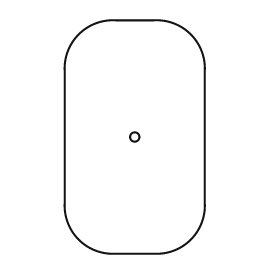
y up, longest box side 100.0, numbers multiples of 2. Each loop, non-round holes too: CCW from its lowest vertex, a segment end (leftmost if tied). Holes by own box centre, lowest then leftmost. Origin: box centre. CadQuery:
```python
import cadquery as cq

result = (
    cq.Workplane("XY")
    .moveTo(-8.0, -50.0)
    .lineTo(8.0, -50.0)
    .threePointArc((24.0, -44.0), (30.0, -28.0))
    .lineTo(30.0, 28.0)
    .threePointArc((24.0, 44.0), (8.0, 50.0))
    .lineTo(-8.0, 50.0)
    .threePointArc((-24.0, 44.0), (-30.0, 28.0))
    .lineTo(-30.0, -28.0)
    .threePointArc((-24.0, -44.0), (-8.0, -50.0))
    .close()
    .moveTo(0.0, 0.0)
    .circle(2.0)
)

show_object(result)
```